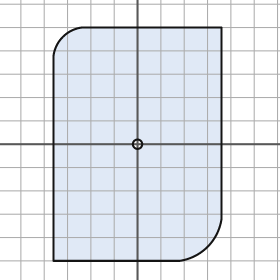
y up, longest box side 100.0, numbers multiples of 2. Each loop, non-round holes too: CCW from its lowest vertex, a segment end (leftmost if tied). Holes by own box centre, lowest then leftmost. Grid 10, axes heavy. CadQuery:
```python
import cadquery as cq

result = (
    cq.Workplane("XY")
    .moveTo(-36.0, -50.0)
    .lineTo(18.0, -50.0)
    .threePointArc((30.0, -44.0), (36.0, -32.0))
    .lineTo(36.0, 50.0)
    .lineTo(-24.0, 50.0)
    .threePointArc((-32.0, 46.0), (-36.0, 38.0))
    .close()
    .moveTo(0.0, 0.0)
    .circle(2.0)
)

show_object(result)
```